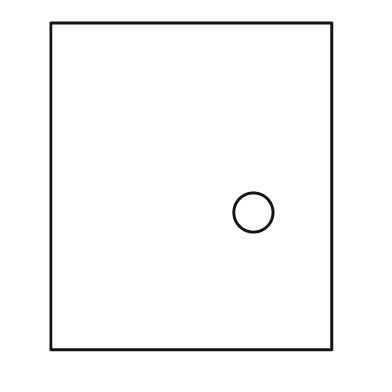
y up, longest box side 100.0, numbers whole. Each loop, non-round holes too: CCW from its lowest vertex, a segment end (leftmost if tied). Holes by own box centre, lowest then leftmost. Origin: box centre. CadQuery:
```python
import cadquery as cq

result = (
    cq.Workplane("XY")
    .moveTo(-43.0, -50.0)
    .lineTo(43.0, -50.0)
    .lineTo(43.0, 50.0)
    .lineTo(-43.0, 50.0)
    .close()
    .moveTo(19.0, -8.0)
    .circle(6.0)
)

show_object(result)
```